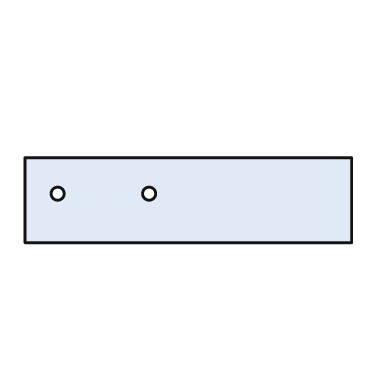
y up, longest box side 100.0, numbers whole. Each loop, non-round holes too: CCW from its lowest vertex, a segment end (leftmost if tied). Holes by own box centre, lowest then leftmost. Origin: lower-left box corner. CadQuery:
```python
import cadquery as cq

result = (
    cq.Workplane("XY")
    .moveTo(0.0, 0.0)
    .lineTo(100.0, 0.0)
    .lineTo(100.0, 26.0)
    .lineTo(0.0, 26.0)
    .close()
    .moveTo(10.0, 15.0)
    .circle(2.0)
    .moveTo(38.0, 15.0)
    .circle(2.0)
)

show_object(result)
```